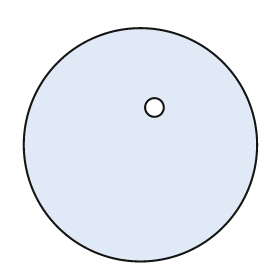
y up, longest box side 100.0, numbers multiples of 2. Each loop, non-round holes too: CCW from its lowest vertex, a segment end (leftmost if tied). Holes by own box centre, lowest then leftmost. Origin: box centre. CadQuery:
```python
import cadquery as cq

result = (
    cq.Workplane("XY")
    .moveTo(0.0, 0.0)
    .circle(50.0)
    .moveTo(6.0, 16.0)
    .circle(4.0)
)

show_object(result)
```